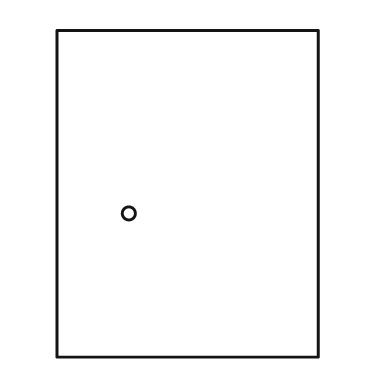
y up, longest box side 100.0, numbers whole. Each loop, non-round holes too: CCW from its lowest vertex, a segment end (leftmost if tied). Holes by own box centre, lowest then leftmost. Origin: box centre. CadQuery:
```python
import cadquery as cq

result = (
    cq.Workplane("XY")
    .moveTo(-40.0, -50.0)
    .lineTo(40.0, -50.0)
    .lineTo(40.0, 50.0)
    .lineTo(-40.0, 50.0)
    .close()
    .moveTo(-18.0, -6.0)
    .circle(2.0)
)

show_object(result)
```